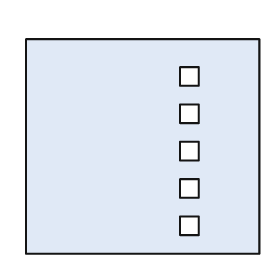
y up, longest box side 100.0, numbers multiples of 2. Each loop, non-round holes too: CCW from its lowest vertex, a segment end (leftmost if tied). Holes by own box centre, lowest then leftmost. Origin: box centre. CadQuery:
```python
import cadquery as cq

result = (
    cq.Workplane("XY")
    .moveTo(-50.0, -46.0)
    .lineTo(50.0, -46.0)
    .lineTo(50.0, 46.0)
    .lineTo(-50.0, 46.0)
    .close()
    .moveTo(16.0, -38.0)
    .lineTo(24.0, -38.0)
    .lineTo(24.0, -30.0)
    .lineTo(16.0, -30.0)
    .close()
    .moveTo(16.0, -22.0)
    .lineTo(24.0, -22.0)
    .lineTo(24.0, -14.0)
    .lineTo(16.0, -14.0)
    .close()
    .moveTo(16.0, -6.0)
    .lineTo(24.0, -6.0)
    .lineTo(24.0, 2.0)
    .lineTo(16.0, 2.0)
    .close()
    .moveTo(16.0, 10.0)
    .lineTo(24.0, 10.0)
    .lineTo(24.0, 18.0)
    .lineTo(16.0, 18.0)
    .close()
    .moveTo(16.0, 26.0)
    .lineTo(24.0, 26.0)
    .lineTo(24.0, 34.0)
    .lineTo(16.0, 34.0)
    .close()
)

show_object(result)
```